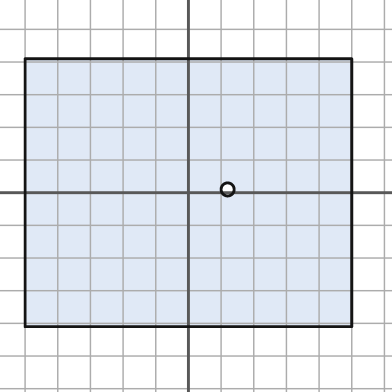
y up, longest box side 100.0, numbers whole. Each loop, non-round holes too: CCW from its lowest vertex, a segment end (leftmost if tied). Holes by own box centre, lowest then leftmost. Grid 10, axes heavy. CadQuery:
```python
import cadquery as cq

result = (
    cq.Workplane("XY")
    .moveTo(-50.0, -41.0)
    .lineTo(50.0, -41.0)
    .lineTo(50.0, 41.0)
    .lineTo(-50.0, 41.0)
    .close()
    .moveTo(12.0, 1.0)
    .circle(2.0)
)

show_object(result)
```